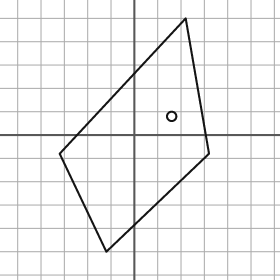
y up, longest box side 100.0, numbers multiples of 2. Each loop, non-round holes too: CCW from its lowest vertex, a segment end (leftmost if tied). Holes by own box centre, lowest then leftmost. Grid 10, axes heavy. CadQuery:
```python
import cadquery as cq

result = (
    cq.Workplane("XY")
    .moveTo(-12.0, -50.0)
    .lineTo(32.0, -8.0)
    .lineTo(22.0, 50.0)
    .lineTo(-32.0, -8.0)
    .close()
    .moveTo(16.0, 8.0)
    .circle(2.0)
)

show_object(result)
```